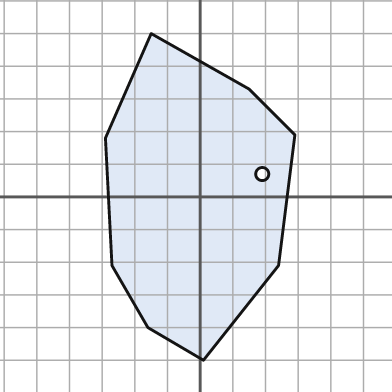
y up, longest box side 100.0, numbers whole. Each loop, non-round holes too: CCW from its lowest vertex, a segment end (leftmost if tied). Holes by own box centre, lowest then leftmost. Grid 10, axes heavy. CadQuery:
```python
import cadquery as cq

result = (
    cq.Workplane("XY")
    .moveTo(1.0, -50.0)
    .lineTo(24.0, -21.0)
    .lineTo(29.0, 19.0)
    .lineTo(15.0, 33.0)
    .lineTo(-15.0, 50.0)
    .lineTo(-29.0, 18.0)
    .lineTo(-27.0, -21.0)
    .lineTo(-16.0, -40.0)
    .close()
    .moveTo(19.0, 7.0)
    .circle(2.0)
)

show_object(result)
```